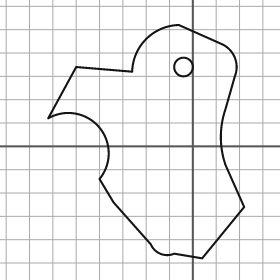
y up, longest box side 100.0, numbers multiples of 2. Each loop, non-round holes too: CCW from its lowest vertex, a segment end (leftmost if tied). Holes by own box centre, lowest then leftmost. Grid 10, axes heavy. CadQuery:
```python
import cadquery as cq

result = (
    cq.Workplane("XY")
    .moveTo(4.0, -48.0)
    .lineTo(22.0, -26.0)
    .lineTo(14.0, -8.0)
    .threePointArc((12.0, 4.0), (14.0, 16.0))
    .lineTo(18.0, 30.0)
    .threePointArc((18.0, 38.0), (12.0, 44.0))
    .lineTo(-6.0, 52.0)
    .threePointArc((-20.0, 46.0), (-26.0, 32.0))
    .lineTo(-50.0, 34.0)
    .lineTo(-62.0, 12.0)
    .threePointArc((-40.0, 8.0), (-40.0, -14.0))
    .lineTo(-34.0, -24.0)
    .lineTo(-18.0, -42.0)
    .threePointArc((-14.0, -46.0), (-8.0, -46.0))
    .close()
    .moveTo(-4.0, 34.0)
    .circle(4.0)
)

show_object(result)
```